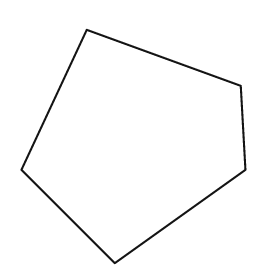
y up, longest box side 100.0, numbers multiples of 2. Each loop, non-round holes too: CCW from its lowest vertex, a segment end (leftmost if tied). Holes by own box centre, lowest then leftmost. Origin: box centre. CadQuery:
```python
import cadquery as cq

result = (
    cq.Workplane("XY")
    .moveTo(-8.0, -50.0)
    .lineTo(48.0, -10.0)
    .lineTo(46.0, 26.0)
    .lineTo(-20.0, 50.0)
    .lineTo(-48.0, -10.0)
    .close()
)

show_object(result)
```